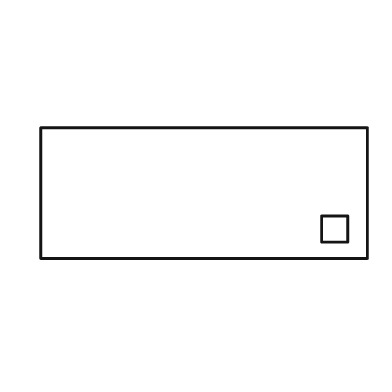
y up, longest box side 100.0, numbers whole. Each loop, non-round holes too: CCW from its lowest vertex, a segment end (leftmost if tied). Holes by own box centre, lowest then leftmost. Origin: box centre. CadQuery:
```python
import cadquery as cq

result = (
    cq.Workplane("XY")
    .moveTo(-50.0, -20.0)
    .lineTo(50.0, -20.0)
    .lineTo(50.0, 20.0)
    .lineTo(-50.0, 20.0)
    .close()
    .moveTo(36.0, -15.0)
    .lineTo(44.0, -15.0)
    .lineTo(44.0, -7.0)
    .lineTo(36.0, -7.0)
    .close()
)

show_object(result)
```